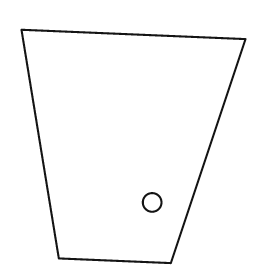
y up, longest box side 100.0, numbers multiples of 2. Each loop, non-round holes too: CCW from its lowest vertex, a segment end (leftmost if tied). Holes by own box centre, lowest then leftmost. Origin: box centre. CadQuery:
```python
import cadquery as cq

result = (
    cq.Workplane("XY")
    .moveTo(16.0, -50.0)
    .lineTo(48.0, 46.0)
    .lineTo(-48.0, 50.0)
    .lineTo(-32.0, -48.0)
    .close()
    .moveTo(8.0, -24.0)
    .circle(4.0)
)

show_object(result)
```